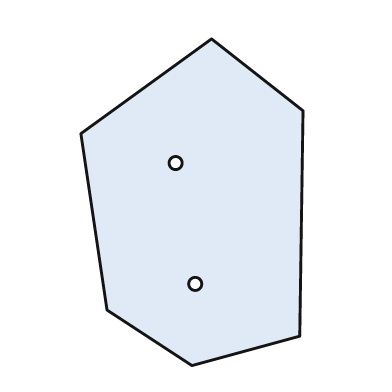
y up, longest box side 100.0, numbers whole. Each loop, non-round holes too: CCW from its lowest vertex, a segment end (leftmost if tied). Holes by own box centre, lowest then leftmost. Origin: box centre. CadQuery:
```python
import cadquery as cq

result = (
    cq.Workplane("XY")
    .moveTo(0.0, -50.0)
    .lineTo(33.0, -41.0)
    .lineTo(34.0, 28.0)
    .lineTo(6.0, 50.0)
    .lineTo(-34.0, 21.0)
    .lineTo(-26.0, -33.0)
    .close()
    .moveTo(1.0, -25.0)
    .circle(2.0)
    .moveTo(-5.0, 12.0)
    .circle(2.0)
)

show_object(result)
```